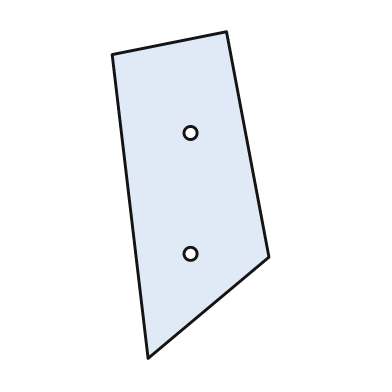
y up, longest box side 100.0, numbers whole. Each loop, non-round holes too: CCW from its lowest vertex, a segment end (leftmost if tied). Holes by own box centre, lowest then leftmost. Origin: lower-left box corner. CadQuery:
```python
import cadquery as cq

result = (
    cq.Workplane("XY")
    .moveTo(11.0, 0.0)
    .lineTo(48.0, 31.0)
    .lineTo(35.0, 100.0)
    .lineTo(0.0, 93.0)
    .close()
    .moveTo(24.0, 32.0)
    .circle(2.0)
    .moveTo(24.0, 69.0)
    .circle(2.0)
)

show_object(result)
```